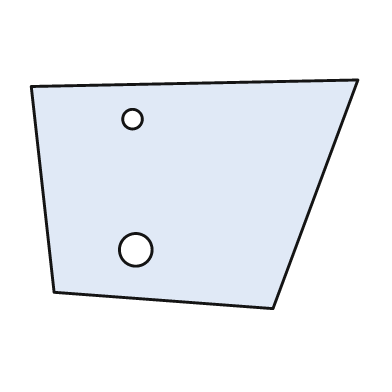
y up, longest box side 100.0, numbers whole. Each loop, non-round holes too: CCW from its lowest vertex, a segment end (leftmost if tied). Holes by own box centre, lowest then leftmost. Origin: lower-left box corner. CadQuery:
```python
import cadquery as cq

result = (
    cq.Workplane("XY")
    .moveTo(74.0, 0.0)
    .lineTo(100.0, 70.0)
    .lineTo(0.0, 68.0)
    .lineTo(7.0, 5.0)
    .close()
    .moveTo(32.0, 18.0)
    .circle(5.0)
    .moveTo(31.0, 58.0)
    .circle(3.0)
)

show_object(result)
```